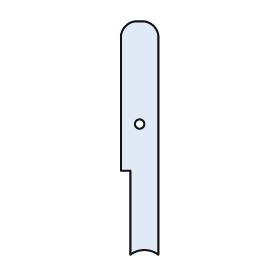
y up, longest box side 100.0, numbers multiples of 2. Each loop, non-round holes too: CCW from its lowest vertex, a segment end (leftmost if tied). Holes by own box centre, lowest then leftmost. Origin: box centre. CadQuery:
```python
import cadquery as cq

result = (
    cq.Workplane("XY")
    .moveTo(-4.0, -50.0)
    .threePointArc((2.0, -48.0), (8.0, -50.0))
    .lineTo(8.0, 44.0)
    .threePointArc((6.0, 48.0), (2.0, 50.0))
    .lineTo(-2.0, 50.0)
    .threePointArc((-6.0, 48.0), (-8.0, 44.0))
    .lineTo(-8.0, -14.0)
    .lineTo(-4.0, -14.0)
    .close()
    .moveTo(0.0, 6.0)
    .circle(2.0)
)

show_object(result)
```